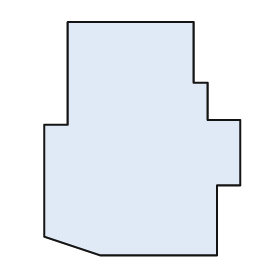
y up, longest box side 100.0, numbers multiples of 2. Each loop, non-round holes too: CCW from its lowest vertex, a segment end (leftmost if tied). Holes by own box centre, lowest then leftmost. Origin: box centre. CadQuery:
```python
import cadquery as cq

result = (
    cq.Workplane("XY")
    .moveTo(-18.0, -50.0)
    .lineTo(32.0, -50.0)
    .lineTo(32.0, -20.0)
    .lineTo(42.0, -20.0)
    .lineTo(42.0, 8.0)
    .lineTo(28.0, 8.0)
    .lineTo(28.0, 24.0)
    .lineTo(22.0, 24.0)
    .lineTo(22.0, 50.0)
    .lineTo(-32.0, 50.0)
    .lineTo(-32.0, 6.0)
    .lineTo(-42.0, 6.0)
    .lineTo(-42.0, -42.0)
    .close()
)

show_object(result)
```